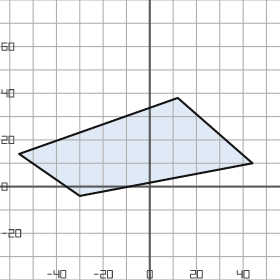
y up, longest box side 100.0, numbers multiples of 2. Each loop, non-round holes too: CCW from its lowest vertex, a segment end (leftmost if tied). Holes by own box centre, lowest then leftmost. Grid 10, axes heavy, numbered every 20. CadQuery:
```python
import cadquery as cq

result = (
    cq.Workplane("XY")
    .moveTo(-30.0, -4.0)
    .lineTo(44.0, 10.0)
    .lineTo(12.0, 38.0)
    .lineTo(-56.0, 14.0)
    .close()
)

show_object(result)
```